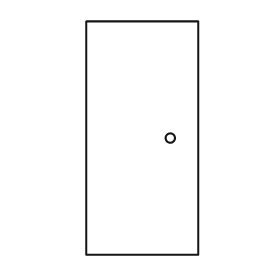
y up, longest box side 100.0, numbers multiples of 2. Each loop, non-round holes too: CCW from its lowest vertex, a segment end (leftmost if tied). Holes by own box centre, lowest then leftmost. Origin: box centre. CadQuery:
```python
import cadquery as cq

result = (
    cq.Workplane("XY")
    .moveTo(-24.0, -50.0)
    .lineTo(24.0, -50.0)
    .lineTo(24.0, 50.0)
    .lineTo(-24.0, 50.0)
    .close()
    .moveTo(12.0, 0.0)
    .circle(2.0)
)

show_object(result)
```